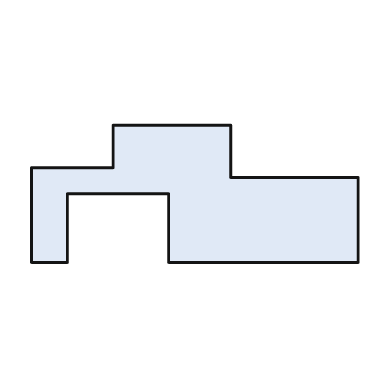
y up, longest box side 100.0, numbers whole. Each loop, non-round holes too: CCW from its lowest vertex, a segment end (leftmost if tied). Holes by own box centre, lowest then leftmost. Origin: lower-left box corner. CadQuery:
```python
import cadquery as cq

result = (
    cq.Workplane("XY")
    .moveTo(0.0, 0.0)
    .lineTo(11.0, 0.0)
    .lineTo(11.0, 21.0)
    .lineTo(42.0, 21.0)
    .lineTo(42.0, 0.0)
    .lineTo(100.0, 0.0)
    .lineTo(100.0, 26.0)
    .lineTo(61.0, 26.0)
    .lineTo(61.0, 42.0)
    .lineTo(25.0, 42.0)
    .lineTo(25.0, 29.0)
    .lineTo(0.0, 29.0)
    .close()
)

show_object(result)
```